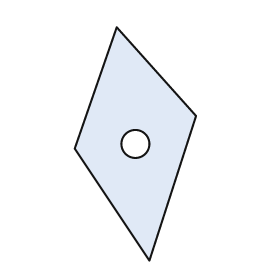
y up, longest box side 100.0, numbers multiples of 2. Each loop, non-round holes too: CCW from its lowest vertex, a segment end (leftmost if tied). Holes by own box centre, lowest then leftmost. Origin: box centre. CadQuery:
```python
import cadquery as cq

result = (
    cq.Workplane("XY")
    .moveTo(6.0, -50.0)
    .lineTo(26.0, 12.0)
    .lineTo(-8.0, 50.0)
    .lineTo(-26.0, -2.0)
    .close()
    .moveTo(0.0, 0.0)
    .circle(6.0)
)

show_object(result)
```